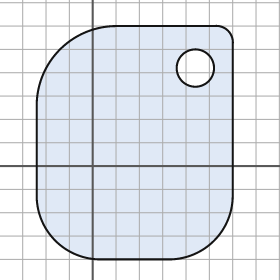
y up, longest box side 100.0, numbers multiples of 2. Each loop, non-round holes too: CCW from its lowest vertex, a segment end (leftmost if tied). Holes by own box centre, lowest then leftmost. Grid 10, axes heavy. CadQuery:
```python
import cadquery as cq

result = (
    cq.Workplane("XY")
    .moveTo(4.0, -40.0)
    .lineTo(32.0, -40.0)
    .threePointArc((52.0, -32.0), (60.0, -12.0))
    .lineTo(60.0, 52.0)
    .threePointArc((58.0, 58.0), (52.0, 60.0))
    .lineTo(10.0, 60.0)
    .threePointArc((-14.0, 50.0), (-24.0, 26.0))
    .lineTo(-24.0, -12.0)
    .threePointArc((-16.0, -32.0), (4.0, -40.0))
    .close()
    .moveTo(44.0, 42.0)
    .circle(8.0)
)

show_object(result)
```